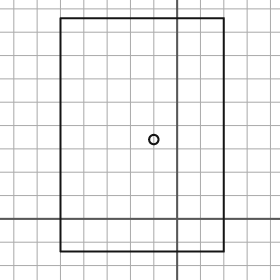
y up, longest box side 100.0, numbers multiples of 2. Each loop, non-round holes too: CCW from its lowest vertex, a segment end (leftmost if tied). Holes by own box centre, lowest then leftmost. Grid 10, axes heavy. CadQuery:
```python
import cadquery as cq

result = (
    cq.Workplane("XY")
    .moveTo(-50.0, -14.0)
    .lineTo(20.0, -14.0)
    .lineTo(20.0, 86.0)
    .lineTo(-50.0, 86.0)
    .close()
    .moveTo(-10.0, 34.0)
    .circle(2.0)
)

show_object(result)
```